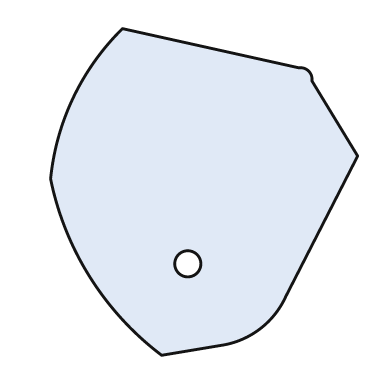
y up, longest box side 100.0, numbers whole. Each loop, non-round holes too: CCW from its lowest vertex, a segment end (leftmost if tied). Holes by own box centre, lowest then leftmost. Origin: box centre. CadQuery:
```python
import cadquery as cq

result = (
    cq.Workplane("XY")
    .moveTo(-13.0, -50.0)
    .lineTo(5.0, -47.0)
    .threePointArc((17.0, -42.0), (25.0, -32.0))
    .lineTo(47.0, 11.0)
    .lineTo(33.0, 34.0)
    .threePointArc((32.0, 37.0), (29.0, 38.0))
    .lineTo(-25.0, 50.0)
    .threePointArc((-40.0, 29.0), (-47.0, 4.0))
    .threePointArc((-35.0, -26.0), (-13.0, -50.0))
    .close()
    .moveTo(-5.0, -22.0)
    .circle(4.0)
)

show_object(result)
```